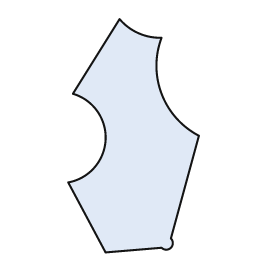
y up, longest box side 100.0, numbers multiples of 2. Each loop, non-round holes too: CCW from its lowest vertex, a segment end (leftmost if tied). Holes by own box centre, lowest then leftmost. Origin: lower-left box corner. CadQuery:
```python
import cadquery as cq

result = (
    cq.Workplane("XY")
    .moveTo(16.0, 0.0)
    .lineTo(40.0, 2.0)
    .threePointArc((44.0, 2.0), (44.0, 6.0))
    .lineTo(56.0, 50.0)
    .threePointArc((40.0, 68.0), (40.0, 92.0))
    .threePointArc((30.0, 94.0), (22.0, 100.0))
    .lineTo(2.0, 68.0)
    .threePointArc((16.0, 48.0), (0.0, 30.0))
    .close()
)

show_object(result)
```